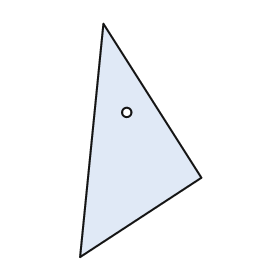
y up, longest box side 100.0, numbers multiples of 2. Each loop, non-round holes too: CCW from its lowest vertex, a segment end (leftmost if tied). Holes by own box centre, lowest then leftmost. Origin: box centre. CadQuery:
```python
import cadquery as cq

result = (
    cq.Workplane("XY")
    .moveTo(-26.0, -50.0)
    .lineTo(26.0, -16.0)
    .lineTo(-16.0, 50.0)
    .close()
    .moveTo(-6.0, 12.0)
    .circle(2.0)
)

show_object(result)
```